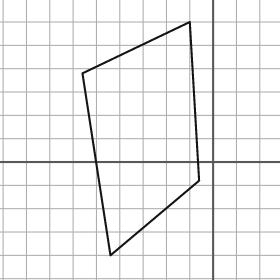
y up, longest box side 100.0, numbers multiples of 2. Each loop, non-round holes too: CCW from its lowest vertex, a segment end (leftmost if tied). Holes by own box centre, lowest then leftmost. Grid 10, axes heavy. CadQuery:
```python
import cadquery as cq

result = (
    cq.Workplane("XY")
    .moveTo(-44.0, -40.0)
    .lineTo(-6.0, -8.0)
    .lineTo(-10.0, 60.0)
    .lineTo(-56.0, 38.0)
    .close()
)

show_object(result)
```